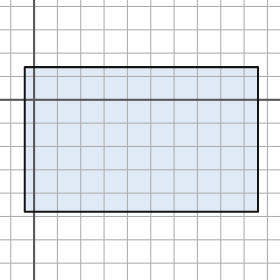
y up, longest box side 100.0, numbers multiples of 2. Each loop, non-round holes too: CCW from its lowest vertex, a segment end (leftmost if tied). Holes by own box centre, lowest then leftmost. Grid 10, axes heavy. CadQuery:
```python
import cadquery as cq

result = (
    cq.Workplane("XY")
    .moveTo(-4.0, -48.0)
    .lineTo(96.0, -48.0)
    .lineTo(96.0, 14.0)
    .lineTo(-4.0, 14.0)
    .close()
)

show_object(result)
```